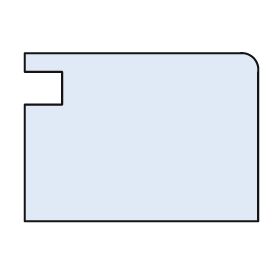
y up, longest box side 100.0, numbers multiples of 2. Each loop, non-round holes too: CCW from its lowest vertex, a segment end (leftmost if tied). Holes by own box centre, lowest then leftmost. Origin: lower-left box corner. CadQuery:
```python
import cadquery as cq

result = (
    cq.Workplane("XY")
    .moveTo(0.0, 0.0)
    .lineTo(100.0, 0.0)
    .lineTo(100.0, 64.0)
    .threePointArc((98.0, 70.0), (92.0, 72.0))
    .lineTo(0.0, 72.0)
    .lineTo(0.0, 64.0)
    .lineTo(16.0, 64.0)
    .lineTo(16.0, 50.0)
    .lineTo(0.0, 50.0)
    .close()
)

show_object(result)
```